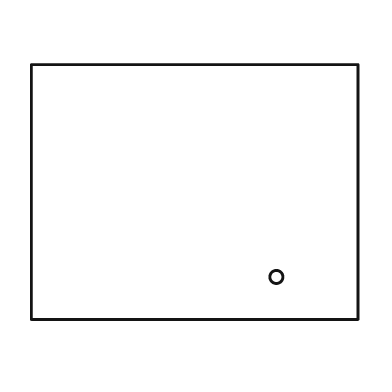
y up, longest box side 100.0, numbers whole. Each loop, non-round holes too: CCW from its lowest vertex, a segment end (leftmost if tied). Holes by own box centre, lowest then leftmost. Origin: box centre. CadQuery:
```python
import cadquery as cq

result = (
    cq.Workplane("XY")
    .moveTo(-50.0, -39.0)
    .lineTo(50.0, -39.0)
    .lineTo(50.0, 39.0)
    .lineTo(-50.0, 39.0)
    .close()
    .moveTo(25.0, -26.0)
    .circle(2.0)
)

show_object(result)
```